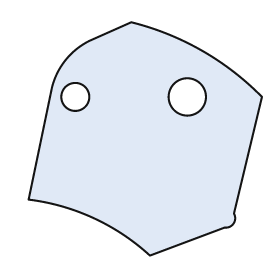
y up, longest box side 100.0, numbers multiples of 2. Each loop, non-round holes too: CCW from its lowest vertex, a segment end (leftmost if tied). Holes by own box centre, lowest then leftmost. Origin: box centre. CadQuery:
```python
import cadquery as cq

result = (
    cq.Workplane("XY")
    .moveTo(2.0, -50.0)
    .lineTo(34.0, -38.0)
    .threePointArc((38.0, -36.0), (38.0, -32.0))
    .lineTo(50.0, 18.0)
    .threePointArc((24.0, 38.0), (-6.0, 50.0))
    .lineTo(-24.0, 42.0)
    .threePointArc((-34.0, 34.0), (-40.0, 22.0))
    .lineTo(-50.0, -26.0)
    .threePointArc((-22.0, -34.0), (2.0, -50.0))
    .close()
    .moveTo(-30.0, 18.0)
    .circle(6.0)
    .moveTo(18.0, 18.0)
    .circle(8.0)
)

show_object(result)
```